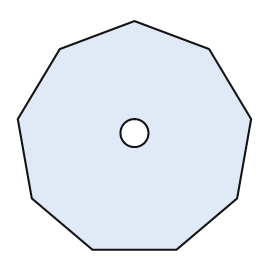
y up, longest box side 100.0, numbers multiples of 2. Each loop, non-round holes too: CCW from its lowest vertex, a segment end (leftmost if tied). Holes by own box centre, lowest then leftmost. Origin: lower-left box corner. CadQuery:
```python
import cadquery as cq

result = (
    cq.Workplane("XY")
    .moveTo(32.0, 0.0)
    .lineTo(68.0, 0.0)
    .lineTo(94.0, 22.0)
    .lineTo(100.0, 56.0)
    .lineTo(82.0, 86.0)
    .lineTo(50.0, 98.0)
    .lineTo(18.0, 86.0)
    .lineTo(0.0, 56.0)
    .lineTo(6.0, 22.0)
    .close()
    .moveTo(50.0, 50.0)
    .circle(6.0)
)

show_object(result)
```